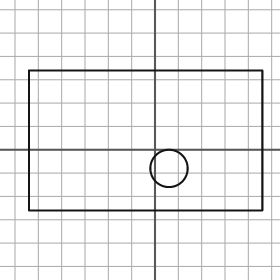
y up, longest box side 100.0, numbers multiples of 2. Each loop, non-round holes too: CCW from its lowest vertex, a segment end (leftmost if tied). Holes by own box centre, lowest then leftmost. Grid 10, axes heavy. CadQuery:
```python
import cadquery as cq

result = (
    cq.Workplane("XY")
    .moveTo(-54.0, -26.0)
    .lineTo(46.0, -26.0)
    .lineTo(46.0, 34.0)
    .lineTo(-54.0, 34.0)
    .close()
    .moveTo(6.0, -8.0)
    .circle(8.0)
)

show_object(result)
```